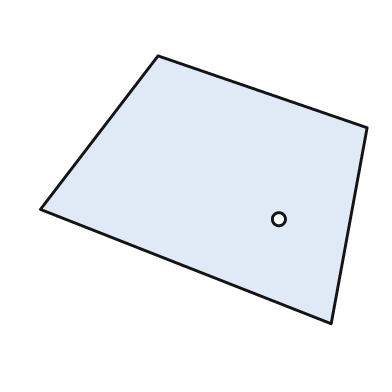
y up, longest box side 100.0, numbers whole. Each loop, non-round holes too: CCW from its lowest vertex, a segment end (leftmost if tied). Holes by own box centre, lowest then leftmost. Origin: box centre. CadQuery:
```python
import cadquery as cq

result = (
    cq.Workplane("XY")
    .moveTo(39.0, -41.0)
    .lineTo(50.0, 19.0)
    .lineTo(-14.0, 41.0)
    .lineTo(-50.0, -6.0)
    .close()
    .moveTo(23.0, -9.0)
    .circle(2.0)
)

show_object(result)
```